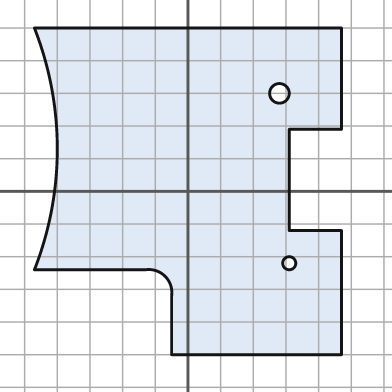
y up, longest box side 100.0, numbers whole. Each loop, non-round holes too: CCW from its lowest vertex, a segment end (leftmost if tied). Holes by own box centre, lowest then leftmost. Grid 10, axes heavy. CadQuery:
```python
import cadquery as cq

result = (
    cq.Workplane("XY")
    .moveTo(-5.0, -50.0)
    .lineTo(47.0, -50.0)
    .lineTo(47.0, -12.0)
    .lineTo(31.0, -12.0)
    .lineTo(31.0, 19.0)
    .lineTo(47.0, 19.0)
    .lineTo(47.0, 50.0)
    .lineTo(-47.0, 50.0)
    .threePointArc((-40.0, 13.0), (-47.0, -24.0))
    .lineTo(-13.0, -24.0)
    .threePointArc((-7.0, -26.0), (-5.0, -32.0))
    .close()
    .moveTo(31.0, -22.0)
    .circle(2.0)
    .moveTo(28.0, 30.0)
    .circle(3.0)
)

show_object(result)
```